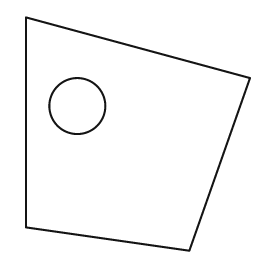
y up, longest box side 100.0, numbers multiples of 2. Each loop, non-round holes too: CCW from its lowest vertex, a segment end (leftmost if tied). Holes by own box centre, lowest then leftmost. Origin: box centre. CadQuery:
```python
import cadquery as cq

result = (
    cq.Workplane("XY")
    .moveTo(22.0, -50.0)
    .lineTo(48.0, 24.0)
    .lineTo(-48.0, 50.0)
    .lineTo(-48.0, -40.0)
    .close()
    .moveTo(-26.0, 12.0)
    .circle(12.0)
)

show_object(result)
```